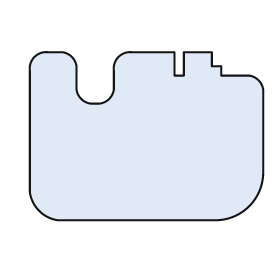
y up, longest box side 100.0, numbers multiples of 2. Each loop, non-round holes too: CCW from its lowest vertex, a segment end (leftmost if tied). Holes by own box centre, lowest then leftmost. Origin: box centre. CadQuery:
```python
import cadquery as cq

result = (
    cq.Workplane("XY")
    .moveTo(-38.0, -36.0)
    .lineTo(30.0, -36.0)
    .threePointArc((44.0, -30.0), (50.0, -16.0))
    .lineTo(50.0, 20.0)
    .threePointArc((48.0, 24.0), (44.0, 26.0))
    .lineTo(32.0, 26.0)
    .lineTo(32.0, 30.0)
    .lineTo(28.0, 30.0)
    .lineTo(28.0, 36.0)
    .lineTo(16.0, 36.0)
    .lineTo(16.0, 26.0)
    .lineTo(12.0, 26.0)
    .lineTo(12.0, 36.0)
    .lineTo(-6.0, 36.0)
    .threePointArc((-12.0, 34.0), (-14.0, 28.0))
    .lineTo(-14.0, 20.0)
    .threePointArc((-16.0, 16.0), (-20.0, 14.0))
    .lineTo(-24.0, 14.0)
    .threePointArc((-28.0, 16.0), (-30.0, 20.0))
    .lineTo(-30.0, 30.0)
    .threePointArc((-32.0, 34.0), (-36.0, 36.0))
    .lineTo(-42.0, 36.0)
    .threePointArc((-48.0, 34.0), (-50.0, 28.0))
    .lineTo(-50.0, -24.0)
    .threePointArc((-46.0, -32.0), (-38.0, -36.0))
    .close()
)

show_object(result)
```